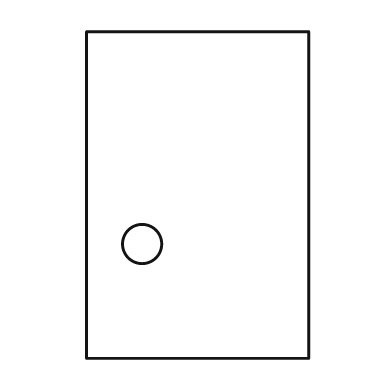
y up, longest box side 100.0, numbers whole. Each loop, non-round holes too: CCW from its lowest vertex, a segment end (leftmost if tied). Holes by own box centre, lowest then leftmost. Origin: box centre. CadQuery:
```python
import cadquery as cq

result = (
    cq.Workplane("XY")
    .moveTo(-34.0, -50.0)
    .lineTo(34.0, -50.0)
    .lineTo(34.0, 50.0)
    .lineTo(-34.0, 50.0)
    .close()
    .moveTo(-17.0, -15.0)
    .circle(6.0)
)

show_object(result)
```